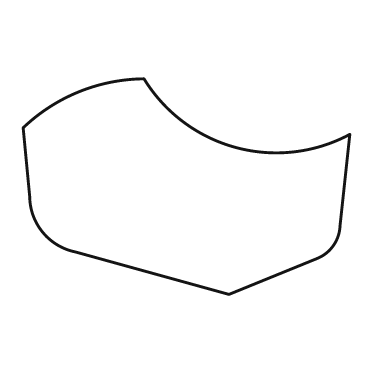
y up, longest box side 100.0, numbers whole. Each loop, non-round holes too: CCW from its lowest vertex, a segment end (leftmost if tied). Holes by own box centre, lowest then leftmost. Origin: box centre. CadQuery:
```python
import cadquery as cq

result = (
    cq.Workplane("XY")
    .moveTo(13.0, -33.0)
    .lineTo(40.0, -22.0)
    .threePointArc((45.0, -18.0), (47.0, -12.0))
    .lineTo(50.0, 16.0)
    .threePointArc((15.0, 12.0), (-13.0, 33.0))
    .threePointArc((-33.0, 29.0), (-50.0, 18.0))
    .lineTo(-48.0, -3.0)
    .threePointArc((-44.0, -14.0), (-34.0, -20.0))
    .close()
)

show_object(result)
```